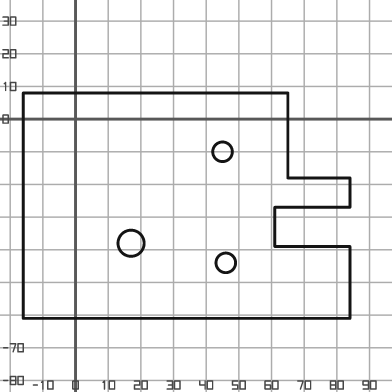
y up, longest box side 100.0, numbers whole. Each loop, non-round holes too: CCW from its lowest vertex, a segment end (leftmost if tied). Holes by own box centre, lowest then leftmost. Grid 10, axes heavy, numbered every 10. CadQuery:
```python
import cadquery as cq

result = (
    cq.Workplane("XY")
    .moveTo(-16.0, -61.0)
    .lineTo(84.0, -61.0)
    .lineTo(84.0, -39.0)
    .lineTo(61.0, -39.0)
    .lineTo(61.0, -27.0)
    .lineTo(84.0, -27.0)
    .lineTo(84.0, -18.0)
    .lineTo(65.0, -18.0)
    .lineTo(65.0, 8.0)
    .lineTo(-16.0, 8.0)
    .close()
    .moveTo(46.0, -44.0)
    .circle(3.0)
    .moveTo(17.0, -38.0)
    .circle(4.0)
    .moveTo(45.0, -10.0)
    .circle(3.0)
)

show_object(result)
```